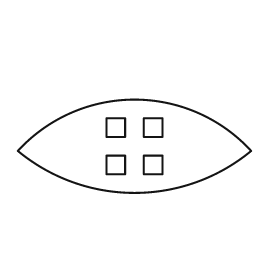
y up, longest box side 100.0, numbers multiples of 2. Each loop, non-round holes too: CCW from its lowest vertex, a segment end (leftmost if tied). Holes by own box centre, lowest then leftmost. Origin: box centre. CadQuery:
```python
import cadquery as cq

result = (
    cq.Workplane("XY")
    .moveTo(-50.0, -2.0)
    .threePointArc((0.0, -20.0), (50.0, -2.0))
    .threePointArc((0.0, 20.0), (-50.0, -2.0))
    .close()
    .moveTo(-12.0, -12.0)
    .lineTo(-4.0, -12.0)
    .lineTo(-4.0, -4.0)
    .lineTo(-12.0, -4.0)
    .close()
    .moveTo(4.0, -12.0)
    .lineTo(12.0, -12.0)
    .lineTo(12.0, -4.0)
    .lineTo(4.0, -4.0)
    .close()
    .moveTo(-12.0, 4.0)
    .lineTo(-4.0, 4.0)
    .lineTo(-4.0, 12.0)
    .lineTo(-12.0, 12.0)
    .close()
    .moveTo(4.0, 4.0)
    .lineTo(12.0, 4.0)
    .lineTo(12.0, 12.0)
    .lineTo(4.0, 12.0)
    .close()
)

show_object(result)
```